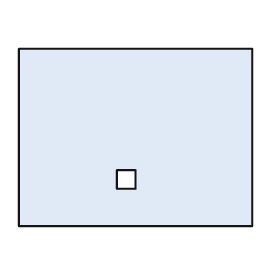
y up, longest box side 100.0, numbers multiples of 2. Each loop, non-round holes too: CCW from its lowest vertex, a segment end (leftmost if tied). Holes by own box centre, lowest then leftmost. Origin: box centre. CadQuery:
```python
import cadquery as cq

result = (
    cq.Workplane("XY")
    .moveTo(-50.0, -38.0)
    .lineTo(50.0, -38.0)
    .lineTo(50.0, 38.0)
    .lineTo(-50.0, 38.0)
    .close()
    .moveTo(-8.0, -22.0)
    .lineTo(0.0, -22.0)
    .lineTo(0.0, -14.0)
    .lineTo(-8.0, -14.0)
    .close()
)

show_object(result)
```